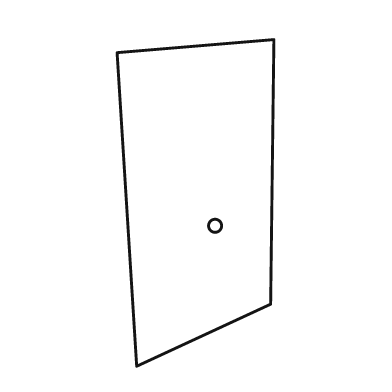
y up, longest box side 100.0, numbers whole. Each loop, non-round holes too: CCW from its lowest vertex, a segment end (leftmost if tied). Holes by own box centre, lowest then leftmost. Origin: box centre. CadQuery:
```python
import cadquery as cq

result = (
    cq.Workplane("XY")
    .moveTo(-18.0, -50.0)
    .lineTo(23.0, -31.0)
    .lineTo(24.0, 50.0)
    .lineTo(-24.0, 46.0)
    .close()
    .moveTo(6.0, -7.0)
    .circle(2.0)
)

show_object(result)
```